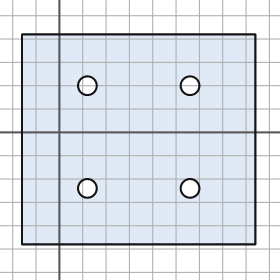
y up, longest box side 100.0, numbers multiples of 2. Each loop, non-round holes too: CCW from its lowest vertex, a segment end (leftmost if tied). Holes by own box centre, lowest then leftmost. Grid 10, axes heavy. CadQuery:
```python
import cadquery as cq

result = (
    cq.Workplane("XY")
    .moveTo(-16.0, -48.0)
    .lineTo(84.0, -48.0)
    .lineTo(84.0, 42.0)
    .lineTo(-16.0, 42.0)
    .close()
    .moveTo(12.0, -24.0)
    .circle(4.0)
    .moveTo(56.0, -24.0)
    .circle(4.0)
    .moveTo(12.0, 20.0)
    .circle(4.0)
    .moveTo(56.0, 20.0)
    .circle(4.0)
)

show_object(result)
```